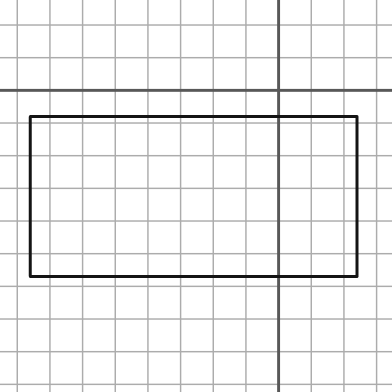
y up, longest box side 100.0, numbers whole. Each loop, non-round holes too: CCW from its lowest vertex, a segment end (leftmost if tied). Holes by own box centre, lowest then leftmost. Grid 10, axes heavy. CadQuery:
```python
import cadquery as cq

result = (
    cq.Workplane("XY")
    .moveTo(-76.0, -57.0)
    .lineTo(24.0, -57.0)
    .lineTo(24.0, -8.0)
    .lineTo(-76.0, -8.0)
    .close()
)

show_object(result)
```